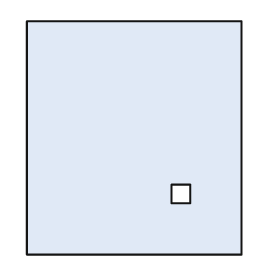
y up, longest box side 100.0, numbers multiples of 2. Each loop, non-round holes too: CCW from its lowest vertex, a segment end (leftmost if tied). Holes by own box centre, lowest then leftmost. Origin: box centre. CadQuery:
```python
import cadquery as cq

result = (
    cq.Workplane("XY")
    .moveTo(-46.0, -50.0)
    .lineTo(46.0, -50.0)
    .lineTo(46.0, 50.0)
    .lineTo(-46.0, 50.0)
    .close()
    .moveTo(16.0, -28.0)
    .lineTo(24.0, -28.0)
    .lineTo(24.0, -20.0)
    .lineTo(16.0, -20.0)
    .close()
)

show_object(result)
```